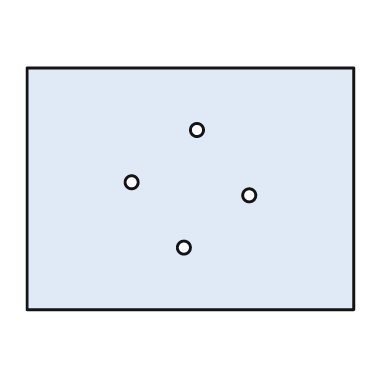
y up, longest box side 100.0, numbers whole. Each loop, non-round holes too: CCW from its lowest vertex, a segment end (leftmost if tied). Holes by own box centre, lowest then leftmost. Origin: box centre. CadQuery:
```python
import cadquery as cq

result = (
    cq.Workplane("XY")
    .moveTo(-50.0, -37.0)
    .lineTo(50.0, -37.0)
    .lineTo(50.0, 37.0)
    .lineTo(-50.0, 37.0)
    .close()
    .moveTo(-2.0, -18.0)
    .circle(2.0)
    .moveTo(18.0, -2.0)
    .circle(2.0)
    .moveTo(-18.0, 2.0)
    .circle(2.0)
    .moveTo(2.0, 18.0)
    .circle(2.0)
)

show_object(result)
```